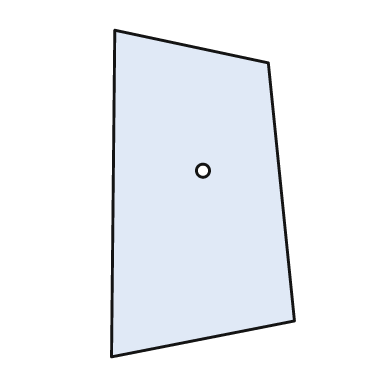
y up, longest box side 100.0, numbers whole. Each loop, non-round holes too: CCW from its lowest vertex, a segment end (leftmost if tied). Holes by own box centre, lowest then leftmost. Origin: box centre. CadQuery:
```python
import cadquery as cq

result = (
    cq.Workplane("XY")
    .moveTo(-28.0, -50.0)
    .lineTo(28.0, -39.0)
    .lineTo(20.0, 40.0)
    .lineTo(-27.0, 50.0)
    .close()
    .moveTo(0.0, 7.0)
    .circle(2.0)
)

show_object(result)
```